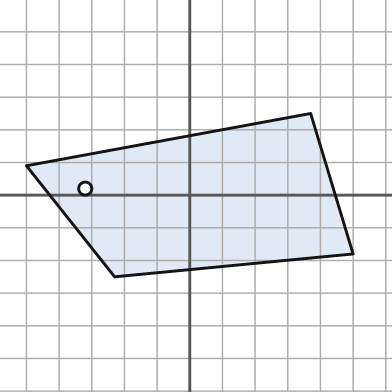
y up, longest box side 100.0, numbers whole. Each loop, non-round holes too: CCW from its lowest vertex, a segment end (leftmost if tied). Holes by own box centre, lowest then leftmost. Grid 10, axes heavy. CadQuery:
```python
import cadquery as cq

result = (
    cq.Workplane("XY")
    .moveTo(-23.0, -25.0)
    .lineTo(50.0, -18.0)
    .lineTo(37.0, 25.0)
    .lineTo(-50.0, 9.0)
    .close()
    .moveTo(-32.0, 2.0)
    .circle(2.0)
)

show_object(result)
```